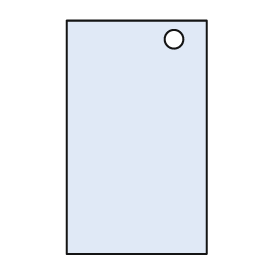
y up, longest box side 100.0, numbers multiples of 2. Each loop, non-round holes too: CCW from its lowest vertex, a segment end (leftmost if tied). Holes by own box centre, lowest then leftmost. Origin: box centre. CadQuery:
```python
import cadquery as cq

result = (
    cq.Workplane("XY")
    .moveTo(-30.0, -50.0)
    .lineTo(30.0, -50.0)
    .lineTo(30.0, 50.0)
    .lineTo(-30.0, 50.0)
    .close()
    .moveTo(16.0, 42.0)
    .circle(4.0)
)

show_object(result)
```